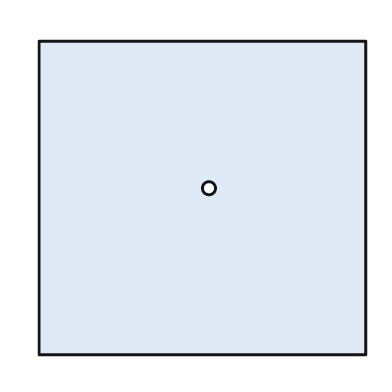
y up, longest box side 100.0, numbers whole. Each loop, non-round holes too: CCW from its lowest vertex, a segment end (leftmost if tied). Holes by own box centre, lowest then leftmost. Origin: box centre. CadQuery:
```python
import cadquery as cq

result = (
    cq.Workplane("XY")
    .moveTo(-50.0, -48.0)
    .lineTo(50.0, -48.0)
    .lineTo(50.0, 48.0)
    .lineTo(-50.0, 48.0)
    .close()
    .moveTo(2.0, 3.0)
    .circle(2.0)
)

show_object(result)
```